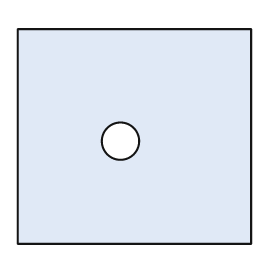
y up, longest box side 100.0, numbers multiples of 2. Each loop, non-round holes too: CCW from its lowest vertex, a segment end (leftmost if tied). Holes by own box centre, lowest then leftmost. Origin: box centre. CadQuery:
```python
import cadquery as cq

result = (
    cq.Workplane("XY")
    .moveTo(-50.0, -46.0)
    .lineTo(50.0, -46.0)
    .lineTo(50.0, 46.0)
    .lineTo(-50.0, 46.0)
    .close()
    .moveTo(-6.0, -2.0)
    .circle(8.0)
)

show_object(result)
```